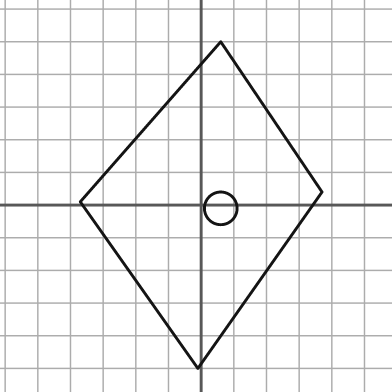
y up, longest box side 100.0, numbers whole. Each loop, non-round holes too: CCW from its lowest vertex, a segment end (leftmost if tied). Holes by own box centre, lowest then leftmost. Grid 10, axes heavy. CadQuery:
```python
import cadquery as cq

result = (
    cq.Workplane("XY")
    .moveTo(-1.0, -50.0)
    .lineTo(37.0, 4.0)
    .lineTo(6.0, 50.0)
    .lineTo(-37.0, 1.0)
    .close()
    .moveTo(6.0, -1.0)
    .circle(5.0)
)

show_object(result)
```